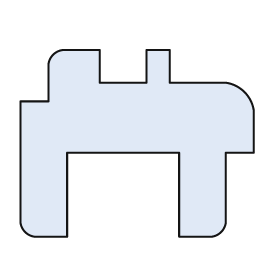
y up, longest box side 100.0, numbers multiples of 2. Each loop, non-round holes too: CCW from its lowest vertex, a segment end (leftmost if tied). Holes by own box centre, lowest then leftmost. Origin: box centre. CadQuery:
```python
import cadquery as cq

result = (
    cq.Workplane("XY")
    .moveTo(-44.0, -40.0)
    .lineTo(-30.0, -40.0)
    .lineTo(-30.0, -4.0)
    .lineTo(18.0, -4.0)
    .lineTo(18.0, -40.0)
    .lineTo(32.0, -40.0)
    .threePointArc((36.0, -38.0), (38.0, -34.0))
    .lineTo(38.0, -4.0)
    .lineTo(50.0, -4.0)
    .lineTo(50.0, 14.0)
    .threePointArc((46.0, 22.0), (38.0, 26.0))
    .lineTo(14.0, 26.0)
    .lineTo(14.0, 40.0)
    .lineTo(4.0, 40.0)
    .lineTo(4.0, 26.0)
    .lineTo(-16.0, 26.0)
    .lineTo(-16.0, 40.0)
    .lineTo(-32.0, 40.0)
    .threePointArc((-36.0, 38.0), (-38.0, 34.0))
    .lineTo(-38.0, 18.0)
    .lineTo(-50.0, 18.0)
    .lineTo(-50.0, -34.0)
    .threePointArc((-48.0, -38.0), (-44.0, -40.0))
    .close()
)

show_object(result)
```